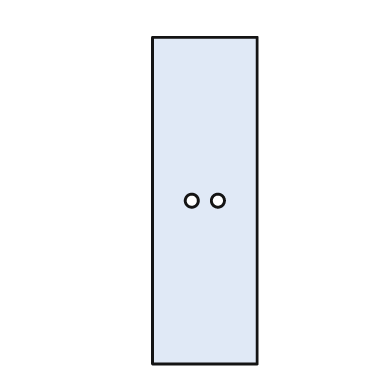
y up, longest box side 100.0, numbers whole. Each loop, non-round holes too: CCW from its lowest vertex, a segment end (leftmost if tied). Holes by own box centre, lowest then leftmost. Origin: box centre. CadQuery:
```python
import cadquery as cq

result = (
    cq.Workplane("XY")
    .moveTo(-16.0, -50.0)
    .lineTo(16.0, -50.0)
    .lineTo(16.0, 50.0)
    .lineTo(-16.0, 50.0)
    .close()
    .moveTo(-4.0, 0.0)
    .circle(2.0)
    .moveTo(4.0, 0.0)
    .circle(2.0)
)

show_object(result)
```